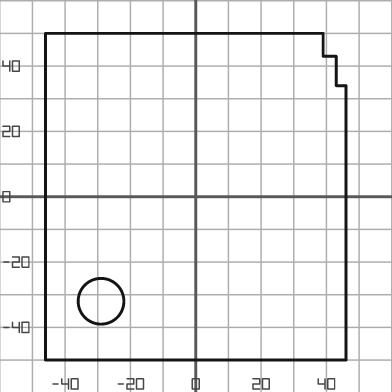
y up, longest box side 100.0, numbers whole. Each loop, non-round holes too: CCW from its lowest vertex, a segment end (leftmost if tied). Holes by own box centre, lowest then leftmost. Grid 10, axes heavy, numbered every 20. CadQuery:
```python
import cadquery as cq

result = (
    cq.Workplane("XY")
    .moveTo(-46.0, -50.0)
    .lineTo(46.0, -50.0)
    .lineTo(46.0, 34.0)
    .lineTo(43.0, 34.0)
    .lineTo(43.0, 43.0)
    .lineTo(39.0, 43.0)
    .lineTo(39.0, 50.0)
    .lineTo(-46.0, 50.0)
    .close()
    .moveTo(-29.0, -32.0)
    .circle(7.0)
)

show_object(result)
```